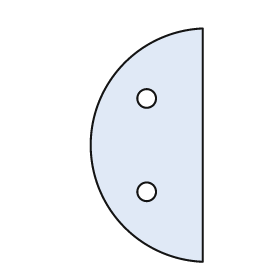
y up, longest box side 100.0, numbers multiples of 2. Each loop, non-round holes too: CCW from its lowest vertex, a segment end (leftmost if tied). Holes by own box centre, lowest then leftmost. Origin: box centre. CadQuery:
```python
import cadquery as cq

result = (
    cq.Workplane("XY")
    .moveTo(24.0, -50.0)
    .lineTo(24.0, 50.0)
    .threePointArc((-24.0, 0.0), (24.0, -50.0))
    .close()
    .moveTo(0.0, -20.0)
    .circle(4.0)
    .moveTo(0.0, 20.0)
    .circle(4.0)
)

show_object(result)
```